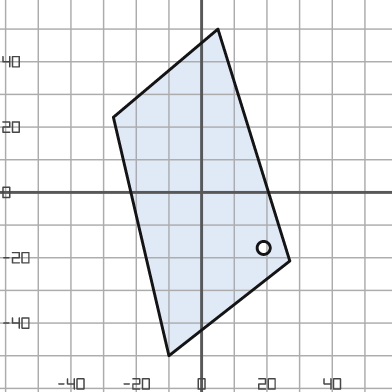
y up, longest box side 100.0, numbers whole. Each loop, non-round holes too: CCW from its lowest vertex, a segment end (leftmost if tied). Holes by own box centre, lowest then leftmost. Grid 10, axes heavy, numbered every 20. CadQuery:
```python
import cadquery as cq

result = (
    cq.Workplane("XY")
    .moveTo(-10.0, -50.0)
    .lineTo(27.0, -21.0)
    .lineTo(5.0, 50.0)
    .lineTo(-27.0, 23.0)
    .close()
    .moveTo(19.0, -17.0)
    .circle(2.0)
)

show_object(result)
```